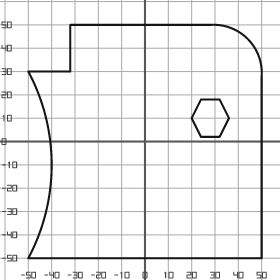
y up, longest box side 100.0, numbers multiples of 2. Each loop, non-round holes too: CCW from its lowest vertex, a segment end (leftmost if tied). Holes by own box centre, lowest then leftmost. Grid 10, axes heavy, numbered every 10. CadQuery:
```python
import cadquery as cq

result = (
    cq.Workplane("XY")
    .moveTo(-50.0, -50.0)
    .lineTo(50.0, -50.0)
    .lineTo(50.0, 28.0)
    .threePointArc((44.0, 44.0), (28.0, 50.0))
    .lineTo(-32.0, 50.0)
    .lineTo(-32.0, 30.0)
    .lineTo(-50.0, 30.0)
    .threePointArc((-40.0, -10.0), (-50.0, -50.0))
    .close()
    .moveTo(24.0, 2.0)
    .lineTo(32.0, 2.0)
    .lineTo(36.0, 10.0)
    .lineTo(32.0, 18.0)
    .lineTo(24.0, 18.0)
    .lineTo(20.0, 10.0)
    .close()
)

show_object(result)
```